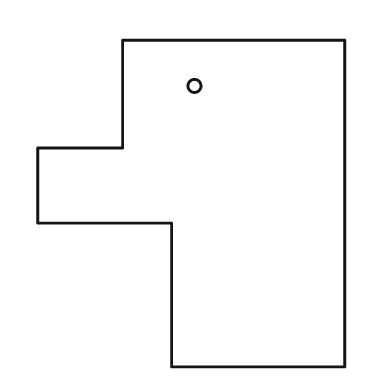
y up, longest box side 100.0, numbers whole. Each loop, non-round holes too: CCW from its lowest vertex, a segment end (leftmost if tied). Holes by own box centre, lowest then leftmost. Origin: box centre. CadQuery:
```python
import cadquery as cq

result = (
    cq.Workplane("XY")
    .moveTo(-6.0, -50.0)
    .lineTo(47.0, -50.0)
    .lineTo(47.0, 50.0)
    .lineTo(-21.0, 50.0)
    .lineTo(-21.0, 17.0)
    .lineTo(-47.0, 17.0)
    .lineTo(-47.0, -6.0)
    .lineTo(-6.0, -6.0)
    .close()
    .moveTo(1.0, 36.0)
    .circle(2.0)
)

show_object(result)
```